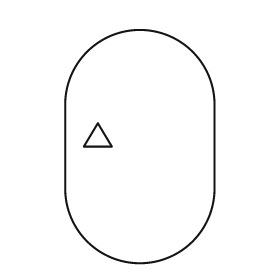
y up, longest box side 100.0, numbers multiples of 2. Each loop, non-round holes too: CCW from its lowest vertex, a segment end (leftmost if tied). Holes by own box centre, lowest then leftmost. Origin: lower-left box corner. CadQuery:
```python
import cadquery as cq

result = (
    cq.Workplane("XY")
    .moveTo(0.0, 32.0)
    .threePointArc((32.0, 0.0), (64.0, 32.0))
    .lineTo(64.0, 68.0)
    .threePointArc((32.0, 100.0), (0.0, 68.0))
    .close()
    .moveTo(8.0, 50.0)
    .lineTo(20.0, 50.0)
    .lineTo(14.0, 60.0)
    .close()
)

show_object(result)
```